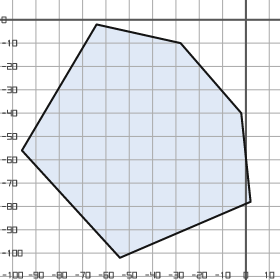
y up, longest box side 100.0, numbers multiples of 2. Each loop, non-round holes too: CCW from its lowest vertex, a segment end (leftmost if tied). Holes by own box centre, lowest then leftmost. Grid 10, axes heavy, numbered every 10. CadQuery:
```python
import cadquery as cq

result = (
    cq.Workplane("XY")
    .moveTo(-54.0, -102.0)
    .lineTo(2.0, -78.0)
    .lineTo(-2.0, -40.0)
    .lineTo(-28.0, -10.0)
    .lineTo(-64.0, -2.0)
    .lineTo(-96.0, -56.0)
    .close()
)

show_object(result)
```